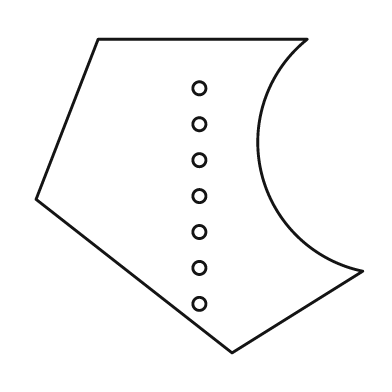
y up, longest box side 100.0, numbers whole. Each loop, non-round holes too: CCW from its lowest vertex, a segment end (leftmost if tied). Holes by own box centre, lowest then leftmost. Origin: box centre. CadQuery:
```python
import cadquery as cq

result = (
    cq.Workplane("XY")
    .moveTo(10.0, -48.0)
    .lineTo(50.0, -23.0)
    .threePointArc((19.0, 7.0), (33.0, 48.0))
    .lineTo(-31.0, 48.0)
    .lineTo(-50.0, -1.0)
    .close()
    .moveTo(0.0, -33.0)
    .circle(2.0)
    .moveTo(0.0, -22.0)
    .circle(2.0)
    .moveTo(0.0, -11.0)
    .circle(2.0)
    .moveTo(0.0, 0.0)
    .circle(2.0)
    .moveTo(0.0, 11.0)
    .circle(2.0)
    .moveTo(0.0, 22.0)
    .circle(2.0)
    .moveTo(0.0, 33.0)
    .circle(2.0)
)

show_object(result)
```